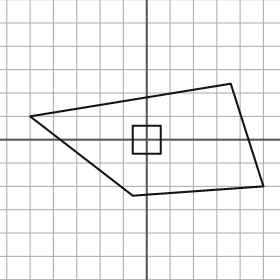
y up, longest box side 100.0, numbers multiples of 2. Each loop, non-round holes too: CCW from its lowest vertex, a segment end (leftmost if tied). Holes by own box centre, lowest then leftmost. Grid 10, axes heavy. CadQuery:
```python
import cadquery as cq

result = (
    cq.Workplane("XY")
    .moveTo(-6.0, -24.0)
    .lineTo(50.0, -20.0)
    .lineTo(36.0, 24.0)
    .lineTo(-50.0, 10.0)
    .close()
    .moveTo(-6.0, -6.0)
    .lineTo(6.0, -6.0)
    .lineTo(6.0, 6.0)
    .lineTo(-6.0, 6.0)
    .close()
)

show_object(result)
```